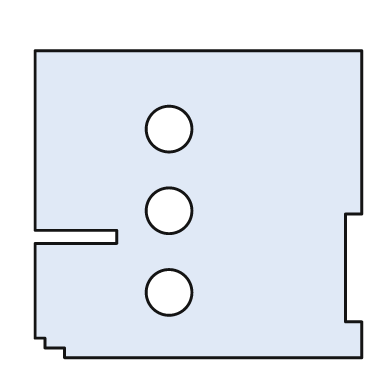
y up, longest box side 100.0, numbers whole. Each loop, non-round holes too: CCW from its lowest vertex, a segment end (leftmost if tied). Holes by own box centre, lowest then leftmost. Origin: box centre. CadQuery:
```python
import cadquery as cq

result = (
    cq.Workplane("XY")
    .moveTo(-41.0, -47.0)
    .lineTo(50.0, -47.0)
    .lineTo(50.0, -36.0)
    .lineTo(45.0, -36.0)
    .lineTo(45.0, -3.0)
    .lineTo(50.0, -3.0)
    .lineTo(50.0, 47.0)
    .lineTo(-50.0, 47.0)
    .lineTo(-50.0, -8.0)
    .lineTo(-25.0, -8.0)
    .lineTo(-25.0, -12.0)
    .lineTo(-50.0, -12.0)
    .lineTo(-50.0, -41.0)
    .lineTo(-47.0, -41.0)
    .lineTo(-47.0, -44.0)
    .lineTo(-41.0, -44.0)
    .close()
    .moveTo(-9.0, -27.0)
    .circle(7.0)
    .moveTo(-9.0, -2.0)
    .circle(7.0)
    .moveTo(-9.0, 23.0)
    .circle(7.0)
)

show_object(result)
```